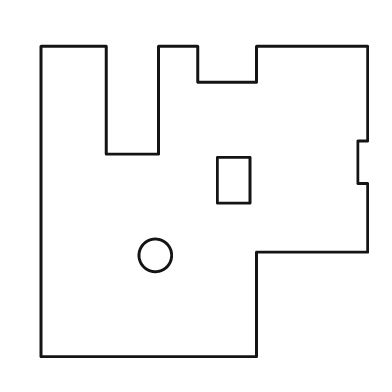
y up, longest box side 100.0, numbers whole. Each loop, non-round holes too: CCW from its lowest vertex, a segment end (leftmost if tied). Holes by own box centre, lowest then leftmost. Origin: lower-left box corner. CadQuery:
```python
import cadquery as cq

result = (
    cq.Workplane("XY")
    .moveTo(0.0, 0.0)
    .lineTo(66.0, 0.0)
    .lineTo(66.0, 32.0)
    .lineTo(100.0, 32.0)
    .lineTo(100.0, 53.0)
    .lineTo(97.0, 53.0)
    .lineTo(97.0, 66.0)
    .lineTo(100.0, 66.0)
    .lineTo(100.0, 95.0)
    .lineTo(66.0, 95.0)
    .lineTo(66.0, 84.0)
    .lineTo(48.0, 84.0)
    .lineTo(48.0, 95.0)
    .lineTo(36.0, 95.0)
    .lineTo(36.0, 62.0)
    .lineTo(20.0, 62.0)
    .lineTo(20.0, 95.0)
    .lineTo(0.0, 95.0)
    .close()
    .moveTo(35.0, 31.0)
    .circle(5.0)
    .moveTo(54.0, 47.0)
    .lineTo(64.0, 47.0)
    .lineTo(64.0, 61.0)
    .lineTo(54.0, 61.0)
    .close()
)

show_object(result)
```